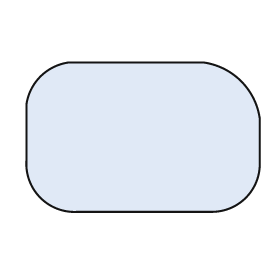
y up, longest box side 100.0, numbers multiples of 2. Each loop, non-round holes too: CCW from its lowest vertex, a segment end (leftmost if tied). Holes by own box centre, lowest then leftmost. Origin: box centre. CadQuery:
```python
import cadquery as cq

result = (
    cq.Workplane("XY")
    .moveTo(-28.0, -32.0)
    .lineTo(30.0, -32.0)
    .threePointArc((44.0, -26.0), (50.0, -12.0))
    .lineTo(50.0, 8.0)
    .threePointArc((42.0, 24.0), (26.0, 32.0))
    .lineTo(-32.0, 32.0)
    .threePointArc((-44.0, 26.0), (-50.0, 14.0))
    .lineTo(-50.0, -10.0)
    .threePointArc((-44.0, -26.0), (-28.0, -32.0))
    .close()
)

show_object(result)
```